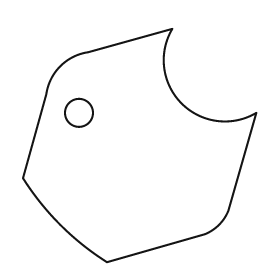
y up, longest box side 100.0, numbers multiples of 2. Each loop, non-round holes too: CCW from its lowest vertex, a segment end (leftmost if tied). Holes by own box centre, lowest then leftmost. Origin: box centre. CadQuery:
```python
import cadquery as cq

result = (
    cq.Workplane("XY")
    .moveTo(-14.0, -50.0)
    .lineTo(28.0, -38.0)
    .threePointArc((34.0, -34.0), (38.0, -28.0))
    .lineTo(50.0, 14.0)
    .threePointArc((18.0, 18.0), (14.0, 50.0))
    .lineTo(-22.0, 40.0)
    .threePointArc((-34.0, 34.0), (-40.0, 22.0))
    .lineTo(-50.0, -14.0)
    .threePointArc((-34.0, -34.0), (-14.0, -50.0))
    .close()
    .moveTo(-26.0, 14.0)
    .circle(6.0)
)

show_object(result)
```